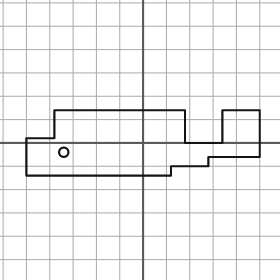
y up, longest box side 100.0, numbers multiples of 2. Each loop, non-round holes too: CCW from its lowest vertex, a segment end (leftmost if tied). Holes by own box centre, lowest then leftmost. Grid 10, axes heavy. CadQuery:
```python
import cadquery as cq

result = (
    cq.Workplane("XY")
    .moveTo(-50.0, -14.0)
    .lineTo(12.0, -14.0)
    .lineTo(12.0, -10.0)
    .lineTo(28.0, -10.0)
    .lineTo(28.0, -6.0)
    .lineTo(50.0, -6.0)
    .lineTo(50.0, 14.0)
    .lineTo(34.0, 14.0)
    .lineTo(34.0, 0.0)
    .lineTo(18.0, 0.0)
    .lineTo(18.0, 14.0)
    .lineTo(-38.0, 14.0)
    .lineTo(-38.0, 2.0)
    .lineTo(-50.0, 2.0)
    .close()
    .moveTo(-34.0, -4.0)
    .circle(2.0)
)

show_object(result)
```